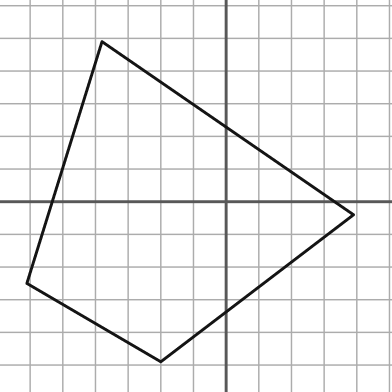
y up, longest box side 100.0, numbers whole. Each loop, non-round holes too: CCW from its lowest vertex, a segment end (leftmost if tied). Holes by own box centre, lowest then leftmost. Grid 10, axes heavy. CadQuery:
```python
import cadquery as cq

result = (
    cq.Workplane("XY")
    .moveTo(-20.0, -49.0)
    .lineTo(39.0, -4.0)
    .lineTo(-38.0, 49.0)
    .lineTo(-61.0, -25.0)
    .close()
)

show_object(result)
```